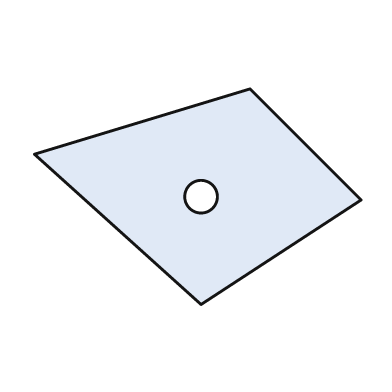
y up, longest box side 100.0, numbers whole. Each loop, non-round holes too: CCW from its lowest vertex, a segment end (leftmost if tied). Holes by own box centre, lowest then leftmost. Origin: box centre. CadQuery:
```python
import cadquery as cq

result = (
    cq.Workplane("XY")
    .moveTo(1.0, -33.0)
    .lineTo(50.0, -1.0)
    .lineTo(16.0, 33.0)
    .lineTo(-50.0, 13.0)
    .close()
    .moveTo(1.0, 0.0)
    .circle(5.0)
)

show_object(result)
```